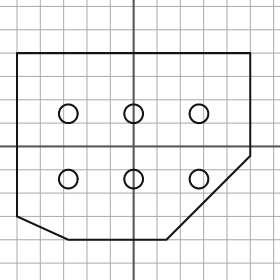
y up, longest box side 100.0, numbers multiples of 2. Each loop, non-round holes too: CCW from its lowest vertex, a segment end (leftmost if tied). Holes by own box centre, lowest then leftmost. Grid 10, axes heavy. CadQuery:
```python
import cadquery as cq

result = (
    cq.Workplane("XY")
    .moveTo(-28.0, -40.0)
    .lineTo(14.0, -40.0)
    .lineTo(50.0, -4.0)
    .lineTo(50.0, 40.0)
    .lineTo(-50.0, 40.0)
    .lineTo(-50.0, -30.0)
    .close()
    .moveTo(-28.0, -14.0)
    .circle(4.0)
    .moveTo(0.0, -14.0)
    .circle(4.0)
    .moveTo(28.0, -14.0)
    .circle(4.0)
    .moveTo(-28.0, 14.0)
    .circle(4.0)
    .moveTo(0.0, 14.0)
    .circle(4.0)
    .moveTo(28.0, 14.0)
    .circle(4.0)
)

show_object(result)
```